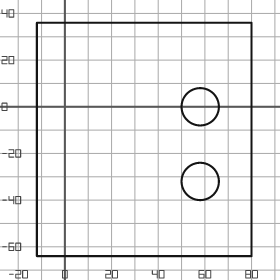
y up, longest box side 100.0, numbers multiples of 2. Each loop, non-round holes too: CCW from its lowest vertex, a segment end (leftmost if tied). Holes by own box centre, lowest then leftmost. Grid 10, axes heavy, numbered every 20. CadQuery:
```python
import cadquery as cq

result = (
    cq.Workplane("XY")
    .moveTo(-12.0, -64.0)
    .lineTo(80.0, -64.0)
    .lineTo(80.0, 36.0)
    .lineTo(-12.0, 36.0)
    .close()
    .moveTo(58.0, -32.0)
    .circle(8.0)
    .moveTo(58.0, 0.0)
    .circle(8.0)
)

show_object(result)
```